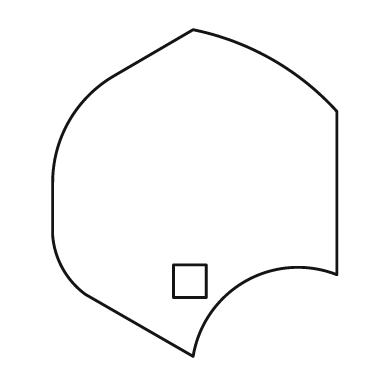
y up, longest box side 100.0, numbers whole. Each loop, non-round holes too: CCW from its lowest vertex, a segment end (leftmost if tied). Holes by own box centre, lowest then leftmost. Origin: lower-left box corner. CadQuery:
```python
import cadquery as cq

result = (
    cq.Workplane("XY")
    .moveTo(43.0, 0.0)
    .threePointArc((59.0, 23.0), (87.0, 25.0))
    .lineTo(87.0, 75.0)
    .threePointArc((67.0, 91.0), (43.0, 100.0))
    .lineTo(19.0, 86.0)
    .threePointArc((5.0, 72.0), (0.0, 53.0))
    .lineTo(0.0, 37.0)
    .threePointArc((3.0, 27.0), (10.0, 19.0))
    .close()
    .moveTo(37.0, 18.0)
    .lineTo(47.0, 18.0)
    .lineTo(47.0, 28.0)
    .lineTo(37.0, 28.0)
    .close()
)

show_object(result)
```